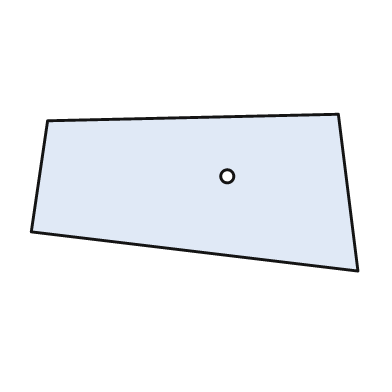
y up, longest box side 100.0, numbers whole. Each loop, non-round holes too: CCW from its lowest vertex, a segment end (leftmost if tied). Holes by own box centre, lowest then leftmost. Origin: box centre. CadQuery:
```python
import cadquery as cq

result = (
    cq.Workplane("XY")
    .moveTo(50.0, -24.0)
    .lineTo(44.0, 24.0)
    .lineTo(-45.0, 22.0)
    .lineTo(-50.0, -12.0)
    .close()
    .moveTo(10.0, 5.0)
    .circle(2.0)
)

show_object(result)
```